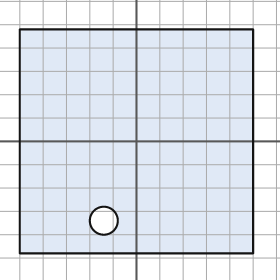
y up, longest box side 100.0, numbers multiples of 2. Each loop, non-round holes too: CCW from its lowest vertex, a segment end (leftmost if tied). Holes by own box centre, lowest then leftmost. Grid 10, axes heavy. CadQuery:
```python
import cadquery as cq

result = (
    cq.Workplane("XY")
    .moveTo(-50.0, -48.0)
    .lineTo(50.0, -48.0)
    .lineTo(50.0, 48.0)
    .lineTo(-50.0, 48.0)
    .close()
    .moveTo(-14.0, -34.0)
    .circle(6.0)
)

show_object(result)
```